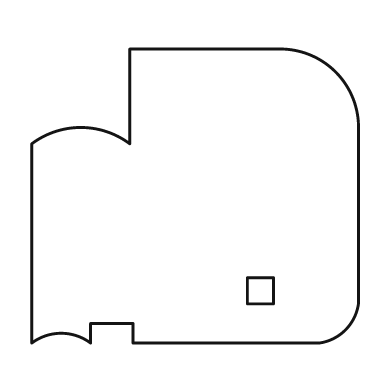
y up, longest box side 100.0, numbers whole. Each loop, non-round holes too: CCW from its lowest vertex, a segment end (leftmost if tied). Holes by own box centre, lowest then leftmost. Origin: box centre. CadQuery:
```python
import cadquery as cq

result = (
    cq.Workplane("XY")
    .moveTo(-50.0, -45.0)
    .threePointArc((-41.0, -42.0), (-32.0, -45.0))
    .lineTo(-32.0, -39.0)
    .lineTo(-19.0, -39.0)
    .lineTo(-19.0, -45.0)
    .lineTo(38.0, -45.0)
    .threePointArc((46.0, -41.0), (50.0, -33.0))
    .lineTo(50.0, 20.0)
    .threePointArc((43.0, 38.0), (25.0, 45.0))
    .lineTo(-20.0, 45.0)
    .lineTo(-20.0, 16.0)
    .threePointArc((-35.0, 21.0), (-50.0, 16.0))
    .close()
    .moveTo(16.0, -33.0)
    .lineTo(24.0, -33.0)
    .lineTo(24.0, -25.0)
    .lineTo(16.0, -25.0)
    .close()
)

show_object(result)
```